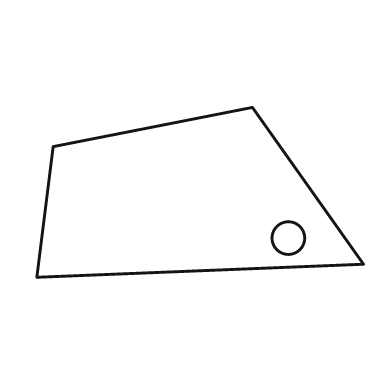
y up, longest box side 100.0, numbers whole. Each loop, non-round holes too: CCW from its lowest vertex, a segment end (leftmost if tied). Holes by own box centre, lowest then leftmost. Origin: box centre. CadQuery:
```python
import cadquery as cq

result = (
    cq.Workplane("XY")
    .moveTo(-50.0, -26.0)
    .lineTo(50.0, -22.0)
    .lineTo(16.0, 26.0)
    .lineTo(-45.0, 14.0)
    .close()
    .moveTo(27.0, -14.0)
    .circle(5.0)
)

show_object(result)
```